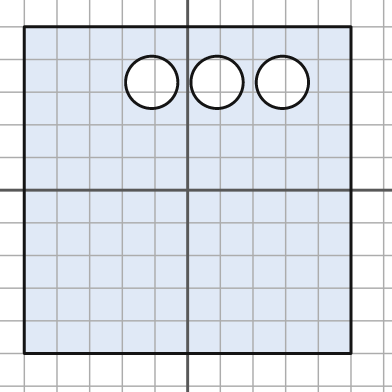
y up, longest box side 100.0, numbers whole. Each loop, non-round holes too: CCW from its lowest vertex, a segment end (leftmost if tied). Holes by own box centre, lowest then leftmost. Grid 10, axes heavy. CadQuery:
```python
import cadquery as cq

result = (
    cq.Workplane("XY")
    .moveTo(-50.0, -50.0)
    .lineTo(50.0, -50.0)
    .lineTo(50.0, 50.0)
    .lineTo(-50.0, 50.0)
    .close()
    .moveTo(-11.0, 33.0)
    .circle(8.0)
    .moveTo(9.0, 33.0)
    .circle(8.0)
    .moveTo(29.0, 33.0)
    .circle(8.0)
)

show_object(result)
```